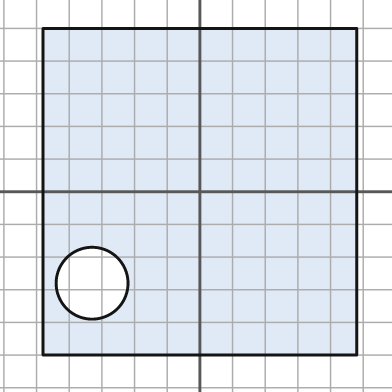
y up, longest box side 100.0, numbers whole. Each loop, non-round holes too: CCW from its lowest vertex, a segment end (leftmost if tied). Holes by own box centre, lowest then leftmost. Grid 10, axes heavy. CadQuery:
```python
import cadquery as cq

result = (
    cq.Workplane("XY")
    .moveTo(-48.0, -50.0)
    .lineTo(48.0, -50.0)
    .lineTo(48.0, 50.0)
    .lineTo(-48.0, 50.0)
    .close()
    .moveTo(-33.0, -28.0)
    .circle(11.0)
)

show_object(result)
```